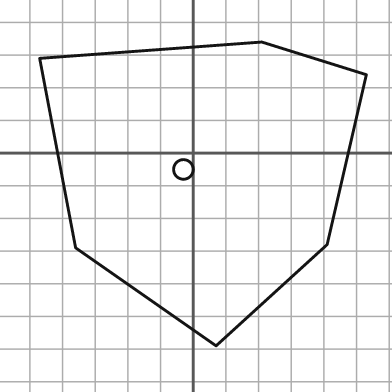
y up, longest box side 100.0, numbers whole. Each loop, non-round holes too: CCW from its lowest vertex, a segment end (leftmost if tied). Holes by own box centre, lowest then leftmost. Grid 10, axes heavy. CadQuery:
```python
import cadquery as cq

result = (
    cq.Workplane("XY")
    .moveTo(7.0, -59.0)
    .lineTo(41.0, -28.0)
    .lineTo(53.0, 24.0)
    .lineTo(21.0, 34.0)
    .lineTo(-47.0, 29.0)
    .lineTo(-36.0, -29.0)
    .close()
    .moveTo(-3.0, -5.0)
    .circle(3.0)
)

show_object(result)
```